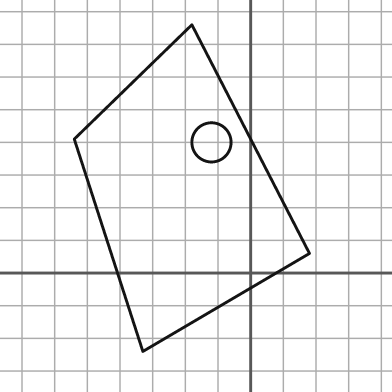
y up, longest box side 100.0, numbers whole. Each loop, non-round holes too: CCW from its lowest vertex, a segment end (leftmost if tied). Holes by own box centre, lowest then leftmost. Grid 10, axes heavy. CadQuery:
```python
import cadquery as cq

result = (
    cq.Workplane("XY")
    .moveTo(-33.0, -24.0)
    .lineTo(18.0, 6.0)
    .lineTo(-18.0, 76.0)
    .lineTo(-54.0, 41.0)
    .close()
    .moveTo(-12.0, 40.0)
    .circle(6.0)
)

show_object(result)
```